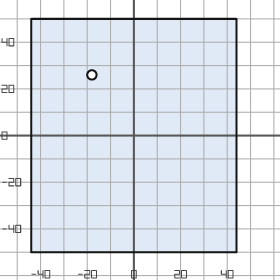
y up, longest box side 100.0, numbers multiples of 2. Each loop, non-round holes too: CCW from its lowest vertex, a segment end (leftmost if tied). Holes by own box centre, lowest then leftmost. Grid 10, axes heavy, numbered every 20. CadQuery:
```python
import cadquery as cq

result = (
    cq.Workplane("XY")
    .moveTo(-44.0, -50.0)
    .lineTo(44.0, -50.0)
    .lineTo(44.0, 50.0)
    .lineTo(-44.0, 50.0)
    .close()
    .moveTo(-18.0, 26.0)
    .circle(2.0)
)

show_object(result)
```